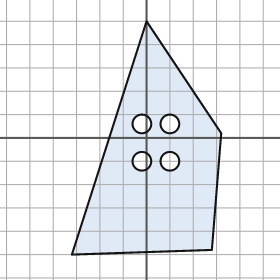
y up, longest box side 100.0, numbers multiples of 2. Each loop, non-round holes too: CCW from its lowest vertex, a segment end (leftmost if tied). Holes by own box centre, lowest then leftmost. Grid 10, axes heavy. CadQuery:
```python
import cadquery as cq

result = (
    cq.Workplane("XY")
    .moveTo(-32.0, -50.0)
    .lineTo(28.0, -48.0)
    .lineTo(32.0, 2.0)
    .lineTo(0.0, 50.0)
    .close()
    .moveTo(-2.0, -10.0)
    .circle(4.0)
    .moveTo(10.0, -10.0)
    .circle(4.0)
    .moveTo(-2.0, 6.0)
    .circle(4.0)
    .moveTo(10.0, 6.0)
    .circle(4.0)
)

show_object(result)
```